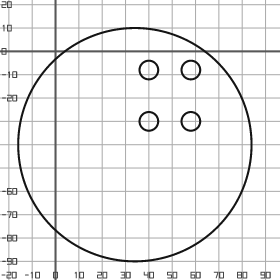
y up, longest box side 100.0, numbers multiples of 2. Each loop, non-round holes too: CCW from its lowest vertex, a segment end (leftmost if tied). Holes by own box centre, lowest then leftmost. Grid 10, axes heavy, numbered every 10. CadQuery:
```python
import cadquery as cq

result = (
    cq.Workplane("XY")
    .moveTo(34.0, -40.0)
    .circle(50.0)
    .moveTo(40.0, -30.0)
    .circle(4.0)
    .moveTo(58.0, -30.0)
    .circle(4.0)
    .moveTo(40.0, -8.0)
    .circle(4.0)
    .moveTo(58.0, -8.0)
    .circle(4.0)
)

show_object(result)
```